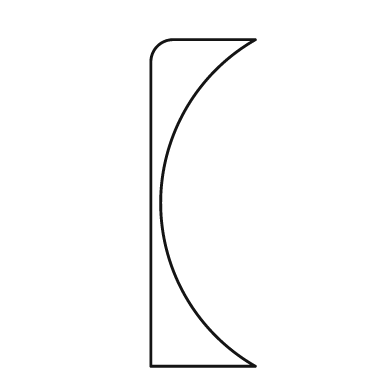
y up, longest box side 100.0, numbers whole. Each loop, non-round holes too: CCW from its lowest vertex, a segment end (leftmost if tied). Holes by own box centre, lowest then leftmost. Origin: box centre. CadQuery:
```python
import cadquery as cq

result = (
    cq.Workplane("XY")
    .moveTo(-16.0, -50.0)
    .lineTo(16.0, -50.0)
    .threePointArc((-13.0, 0.0), (16.0, 50.0))
    .lineTo(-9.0, 50.0)
    .threePointArc((-14.0, 48.0), (-16.0, 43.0))
    .close()
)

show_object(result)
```